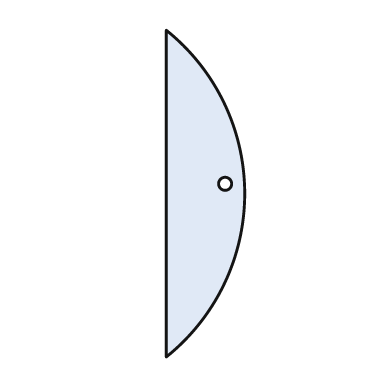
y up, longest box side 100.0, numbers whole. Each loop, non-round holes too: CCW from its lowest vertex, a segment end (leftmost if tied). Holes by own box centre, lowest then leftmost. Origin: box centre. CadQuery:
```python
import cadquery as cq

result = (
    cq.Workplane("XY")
    .moveTo(-12.0, -50.0)
    .threePointArc((12.0, 0.0), (-12.0, 50.0))
    .close()
    .moveTo(6.0, 3.0)
    .circle(2.0)
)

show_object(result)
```